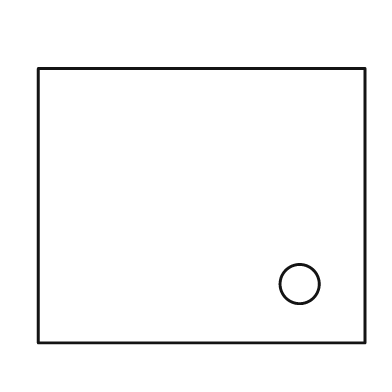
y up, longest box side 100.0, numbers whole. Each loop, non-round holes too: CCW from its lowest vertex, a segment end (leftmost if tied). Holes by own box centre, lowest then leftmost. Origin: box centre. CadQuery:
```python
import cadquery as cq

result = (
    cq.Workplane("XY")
    .moveTo(-50.0, -42.0)
    .lineTo(50.0, -42.0)
    .lineTo(50.0, 42.0)
    .lineTo(-50.0, 42.0)
    .close()
    .moveTo(30.0, -24.0)
    .circle(6.0)
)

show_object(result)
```